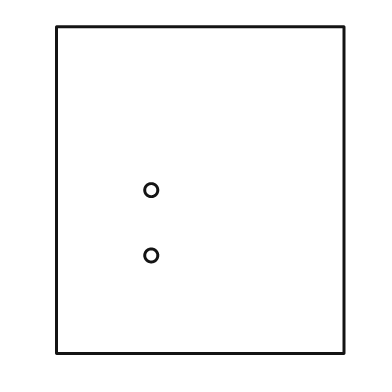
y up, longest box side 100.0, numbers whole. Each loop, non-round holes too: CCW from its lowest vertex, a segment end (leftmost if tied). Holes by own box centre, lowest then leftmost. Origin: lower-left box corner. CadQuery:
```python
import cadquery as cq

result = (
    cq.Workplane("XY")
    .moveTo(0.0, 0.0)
    .lineTo(88.0, 0.0)
    .lineTo(88.0, 100.0)
    .lineTo(0.0, 100.0)
    .close()
    .moveTo(29.0, 30.0)
    .circle(2.0)
    .moveTo(29.0, 50.0)
    .circle(2.0)
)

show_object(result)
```